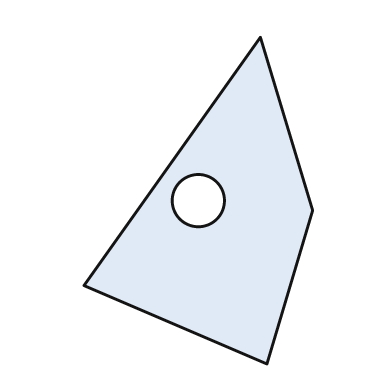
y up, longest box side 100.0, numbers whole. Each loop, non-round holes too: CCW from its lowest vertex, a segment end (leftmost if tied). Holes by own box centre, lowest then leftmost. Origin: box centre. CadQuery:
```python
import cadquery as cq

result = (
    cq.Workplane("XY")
    .moveTo(21.0, -50.0)
    .lineTo(35.0, -3.0)
    .lineTo(19.0, 50.0)
    .lineTo(-35.0, -26.0)
    .close()
    .moveTo(0.0, 0.0)
    .circle(8.0)
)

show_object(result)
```